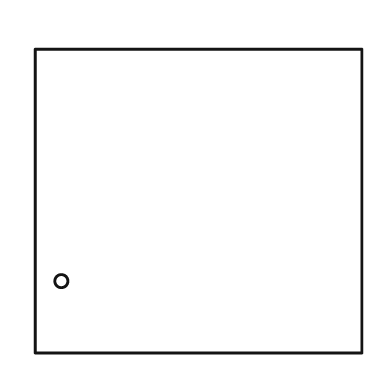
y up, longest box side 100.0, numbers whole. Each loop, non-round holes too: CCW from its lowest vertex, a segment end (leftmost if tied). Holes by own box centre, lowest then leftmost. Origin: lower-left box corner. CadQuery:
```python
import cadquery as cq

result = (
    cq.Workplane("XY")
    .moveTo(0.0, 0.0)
    .lineTo(100.0, 0.0)
    .lineTo(100.0, 93.0)
    .lineTo(0.0, 93.0)
    .close()
    .moveTo(8.0, 22.0)
    .circle(2.0)
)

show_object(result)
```